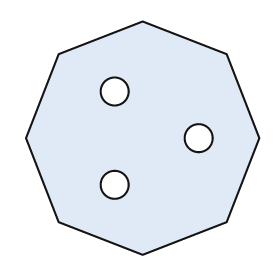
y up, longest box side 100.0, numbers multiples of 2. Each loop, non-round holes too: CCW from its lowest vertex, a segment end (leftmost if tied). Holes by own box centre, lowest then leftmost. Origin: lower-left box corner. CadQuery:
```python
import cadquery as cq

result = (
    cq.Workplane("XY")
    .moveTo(50.0, 0.0)
    .lineTo(86.0, 14.0)
    .lineTo(100.0, 50.0)
    .lineTo(86.0, 86.0)
    .lineTo(50.0, 100.0)
    .lineTo(14.0, 86.0)
    .lineTo(0.0, 50.0)
    .lineTo(14.0, 14.0)
    .close()
    .moveTo(38.0, 30.0)
    .circle(6.0)
    .moveTo(74.0, 50.0)
    .circle(6.0)
    .moveTo(38.0, 70.0)
    .circle(6.0)
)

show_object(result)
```